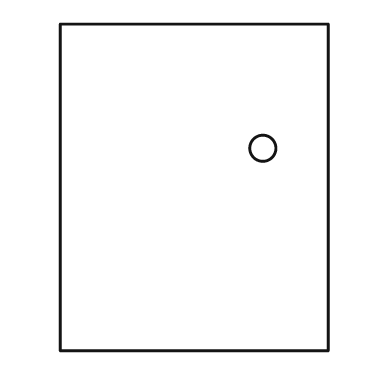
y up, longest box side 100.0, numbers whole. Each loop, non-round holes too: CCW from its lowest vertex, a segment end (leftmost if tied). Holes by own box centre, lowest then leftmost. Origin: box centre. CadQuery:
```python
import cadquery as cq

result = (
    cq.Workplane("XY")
    .moveTo(-41.0, -50.0)
    .lineTo(41.0, -50.0)
    .lineTo(41.0, 50.0)
    .lineTo(-41.0, 50.0)
    .close()
    .moveTo(21.0, 12.0)
    .circle(4.0)
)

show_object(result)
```